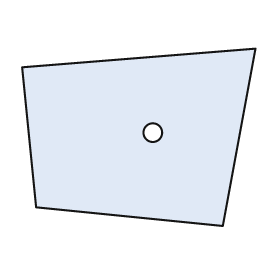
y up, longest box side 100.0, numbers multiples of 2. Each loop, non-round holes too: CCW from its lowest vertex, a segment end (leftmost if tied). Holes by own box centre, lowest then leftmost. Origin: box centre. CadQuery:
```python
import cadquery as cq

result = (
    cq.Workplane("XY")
    .moveTo(36.0, -38.0)
    .lineTo(50.0, 38.0)
    .lineTo(-50.0, 30.0)
    .lineTo(-44.0, -30.0)
    .close()
    .moveTo(6.0, 2.0)
    .circle(4.0)
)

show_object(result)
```